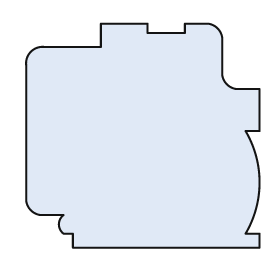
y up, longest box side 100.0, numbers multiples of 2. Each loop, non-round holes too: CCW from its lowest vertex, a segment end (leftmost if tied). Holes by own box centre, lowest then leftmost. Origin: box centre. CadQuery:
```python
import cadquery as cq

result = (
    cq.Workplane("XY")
    .moveTo(-30.0, -48.0)
    .lineTo(50.0, -48.0)
    .lineTo(50.0, -42.0)
    .lineTo(44.0, -42.0)
    .threePointArc((50.0, -20.0), (44.0, 2.0))
    .lineTo(50.0, 2.0)
    .lineTo(50.0, 20.0)
    .lineTo(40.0, 20.0)
    .threePointArc((36.0, 22.0), (34.0, 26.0))
    .lineTo(34.0, 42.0)
    .threePointArc((32.0, 46.0), (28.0, 48.0))
    .lineTo(18.0, 48.0)
    .lineTo(18.0, 44.0)
    .lineTo(2.0, 44.0)
    .lineTo(2.0, 48.0)
    .lineTo(-18.0, 48.0)
    .lineTo(-18.0, 38.0)
    .lineTo(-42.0, 38.0)
    .threePointArc((-48.0, 36.0), (-50.0, 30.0))
    .lineTo(-50.0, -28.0)
    .threePointArc((-48.0, -32.0), (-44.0, -34.0))
    .lineTo(-34.0, -34.0)
    .threePointArc((-36.0, -38.0), (-34.0, -42.0))
    .lineTo(-30.0, -42.0)
    .close()
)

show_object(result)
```